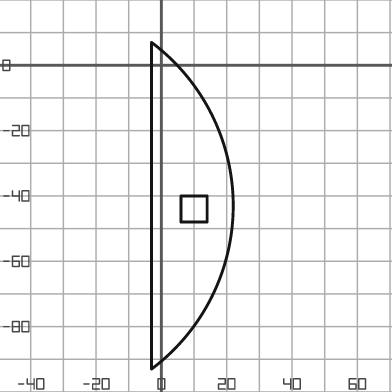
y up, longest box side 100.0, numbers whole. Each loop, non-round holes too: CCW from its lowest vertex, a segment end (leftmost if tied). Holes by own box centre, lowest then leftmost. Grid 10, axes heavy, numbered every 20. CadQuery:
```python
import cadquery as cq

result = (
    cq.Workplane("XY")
    .moveTo(-3.0, -93.0)
    .threePointArc((22.0, -43.0), (-3.0, 7.0))
    .close()
    .moveTo(6.0, -48.0)
    .lineTo(14.0, -48.0)
    .lineTo(14.0, -40.0)
    .lineTo(6.0, -40.0)
    .close()
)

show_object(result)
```